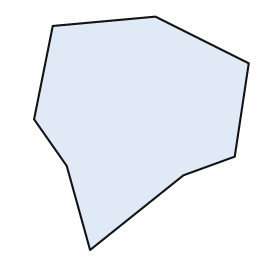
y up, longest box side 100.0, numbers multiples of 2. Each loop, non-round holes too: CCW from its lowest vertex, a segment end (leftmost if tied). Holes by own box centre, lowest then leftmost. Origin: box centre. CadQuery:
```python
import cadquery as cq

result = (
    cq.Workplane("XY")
    .moveTo(-22.0, -50.0)
    .lineTo(18.0, -18.0)
    .lineTo(40.0, -10.0)
    .lineTo(46.0, 30.0)
    .lineTo(6.0, 50.0)
    .lineTo(-38.0, 46.0)
    .lineTo(-46.0, 6.0)
    .lineTo(-32.0, -14.0)
    .close()
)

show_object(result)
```